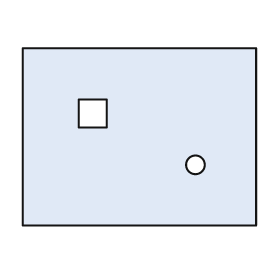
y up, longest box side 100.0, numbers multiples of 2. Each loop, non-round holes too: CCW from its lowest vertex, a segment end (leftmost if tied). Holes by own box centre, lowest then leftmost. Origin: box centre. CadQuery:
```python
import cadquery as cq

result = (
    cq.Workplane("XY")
    .moveTo(-50.0, -38.0)
    .lineTo(50.0, -38.0)
    .lineTo(50.0, 38.0)
    .lineTo(-50.0, 38.0)
    .close()
    .moveTo(24.0, -12.0)
    .circle(4.0)
    .moveTo(-26.0, 4.0)
    .lineTo(-14.0, 4.0)
    .lineTo(-14.0, 16.0)
    .lineTo(-26.0, 16.0)
    .close()
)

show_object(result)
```